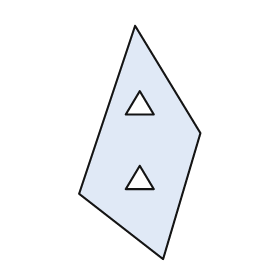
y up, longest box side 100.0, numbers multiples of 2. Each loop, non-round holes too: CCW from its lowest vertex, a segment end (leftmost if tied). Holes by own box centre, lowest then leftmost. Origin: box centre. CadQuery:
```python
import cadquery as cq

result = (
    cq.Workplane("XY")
    .moveTo(10.0, -50.0)
    .lineTo(26.0, 4.0)
    .lineTo(-2.0, 50.0)
    .lineTo(-26.0, -22.0)
    .close()
    .moveTo(-6.0, -20.0)
    .lineTo(6.0, -20.0)
    .lineTo(0.0, -10.0)
    .close()
    .moveTo(-6.0, 12.0)
    .lineTo(6.0, 12.0)
    .lineTo(0.0, 22.0)
    .close()
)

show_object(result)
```